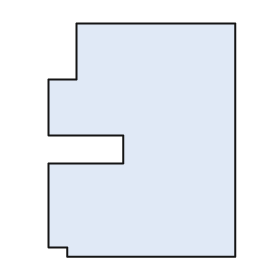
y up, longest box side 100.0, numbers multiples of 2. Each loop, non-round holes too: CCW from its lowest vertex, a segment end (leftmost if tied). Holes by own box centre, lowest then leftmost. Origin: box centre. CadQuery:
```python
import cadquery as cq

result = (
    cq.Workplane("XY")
    .moveTo(-32.0, -50.0)
    .lineTo(40.0, -50.0)
    .lineTo(40.0, 50.0)
    .lineTo(-28.0, 50.0)
    .lineTo(-28.0, 26.0)
    .lineTo(-40.0, 26.0)
    .lineTo(-40.0, 2.0)
    .lineTo(-8.0, 2.0)
    .lineTo(-8.0, -10.0)
    .lineTo(-40.0, -10.0)
    .lineTo(-40.0, -46.0)
    .lineTo(-32.0, -46.0)
    .close()
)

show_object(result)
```